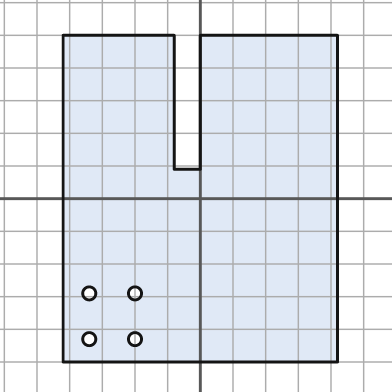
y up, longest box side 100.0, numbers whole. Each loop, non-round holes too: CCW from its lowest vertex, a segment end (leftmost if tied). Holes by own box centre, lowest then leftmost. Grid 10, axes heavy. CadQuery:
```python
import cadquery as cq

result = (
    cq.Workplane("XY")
    .moveTo(-42.0, -50.0)
    .lineTo(42.0, -50.0)
    .lineTo(42.0, 50.0)
    .lineTo(0.0, 50.0)
    .lineTo(0.0, 9.0)
    .lineTo(-8.0, 9.0)
    .lineTo(-8.0, 50.0)
    .lineTo(-42.0, 50.0)
    .close()
    .moveTo(-34.0, -43.0)
    .circle(2.0)
    .moveTo(-20.0, -43.0)
    .circle(2.0)
    .moveTo(-34.0, -29.0)
    .circle(2.0)
    .moveTo(-20.0, -29.0)
    .circle(2.0)
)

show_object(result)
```